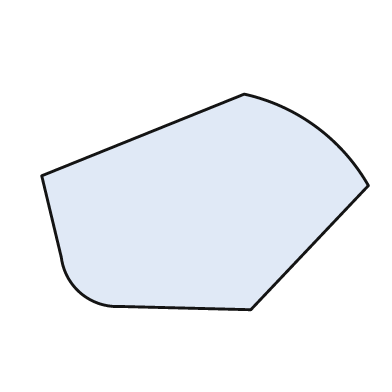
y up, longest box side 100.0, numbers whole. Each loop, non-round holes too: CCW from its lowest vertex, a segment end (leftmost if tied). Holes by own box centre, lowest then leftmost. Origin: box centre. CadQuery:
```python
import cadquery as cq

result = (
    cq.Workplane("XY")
    .moveTo(14.0, -33.0)
    .lineTo(50.0, 5.0)
    .threePointArc((34.0, 23.0), (12.0, 33.0))
    .lineTo(-50.0, 8.0)
    .lineTo(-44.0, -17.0)
    .threePointArc((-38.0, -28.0), (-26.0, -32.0))
    .close()
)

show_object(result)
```